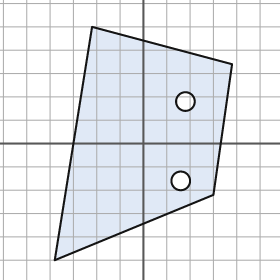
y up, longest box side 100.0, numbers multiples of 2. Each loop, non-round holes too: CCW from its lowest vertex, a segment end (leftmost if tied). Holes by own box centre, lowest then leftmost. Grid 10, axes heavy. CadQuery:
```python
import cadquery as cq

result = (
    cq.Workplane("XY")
    .moveTo(-38.0, -50.0)
    .lineTo(30.0, -22.0)
    .lineTo(38.0, 34.0)
    .lineTo(-22.0, 50.0)
    .close()
    .moveTo(16.0, -16.0)
    .circle(4.0)
    .moveTo(18.0, 18.0)
    .circle(4.0)
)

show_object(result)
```